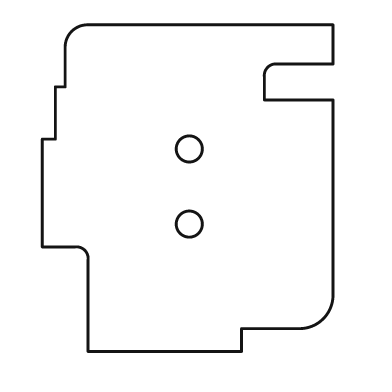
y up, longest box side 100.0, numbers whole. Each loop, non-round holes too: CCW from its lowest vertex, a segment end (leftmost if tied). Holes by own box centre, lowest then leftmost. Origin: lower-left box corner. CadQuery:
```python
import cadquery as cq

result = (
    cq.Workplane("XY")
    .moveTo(14.0, 0.0)
    .lineTo(61.0, 0.0)
    .lineTo(61.0, 7.0)
    .lineTo(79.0, 7.0)
    .threePointArc((86.0, 10.0), (89.0, 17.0))
    .lineTo(89.0, 77.0)
    .lineTo(68.0, 77.0)
    .lineTo(68.0, 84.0)
    .threePointArc((69.0, 87.0), (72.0, 88.0))
    .lineTo(89.0, 88.0)
    .lineTo(89.0, 100.0)
    .lineTo(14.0, 100.0)
    .threePointArc((9.0, 98.0), (7.0, 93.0))
    .lineTo(7.0, 81.0)
    .lineTo(4.0, 81.0)
    .lineTo(4.0, 65.0)
    .lineTo(0.0, 65.0)
    .lineTo(0.0, 32.0)
    .lineTo(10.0, 32.0)
    .threePointArc((13.0, 31.0), (14.0, 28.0))
    .close()
    .moveTo(45.0, 39.0)
    .circle(4.0)
    .moveTo(45.0, 62.0)
    .circle(4.0)
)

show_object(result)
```